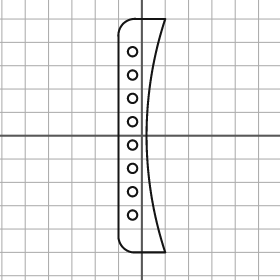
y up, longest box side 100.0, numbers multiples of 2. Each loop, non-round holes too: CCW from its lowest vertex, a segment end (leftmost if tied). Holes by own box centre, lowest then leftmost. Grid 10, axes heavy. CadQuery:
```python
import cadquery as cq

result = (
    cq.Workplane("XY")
    .moveTo(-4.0, -50.0)
    .lineTo(10.0, -50.0)
    .threePointArc((2.0, 0.0), (10.0, 50.0))
    .lineTo(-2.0, 50.0)
    .threePointArc((-8.0, 48.0), (-10.0, 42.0))
    .lineTo(-10.0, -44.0)
    .threePointArc((-8.0, -48.0), (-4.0, -50.0))
    .close()
    .moveTo(-4.0, -34.0)
    .circle(2.0)
    .moveTo(-4.0, -24.0)
    .circle(2.0)
    .moveTo(-4.0, -14.0)
    .circle(2.0)
    .moveTo(-4.0, -4.0)
    .circle(2.0)
    .moveTo(-4.0, 6.0)
    .circle(2.0)
    .moveTo(-4.0, 16.0)
    .circle(2.0)
    .moveTo(-4.0, 26.0)
    .circle(2.0)
    .moveTo(-4.0, 36.0)
    .circle(2.0)
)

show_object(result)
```